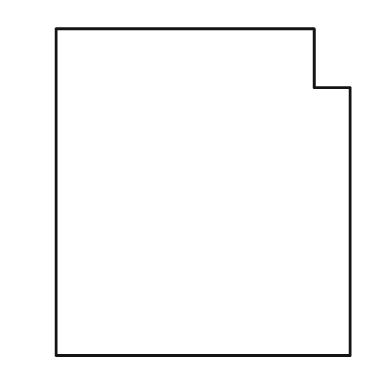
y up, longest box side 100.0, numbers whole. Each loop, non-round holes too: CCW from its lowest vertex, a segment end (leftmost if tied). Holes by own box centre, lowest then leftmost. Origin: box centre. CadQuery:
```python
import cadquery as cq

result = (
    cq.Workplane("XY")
    .moveTo(-45.0, -50.0)
    .lineTo(45.0, -50.0)
    .lineTo(45.0, 32.0)
    .lineTo(34.0, 32.0)
    .lineTo(34.0, 50.0)
    .lineTo(-45.0, 50.0)
    .close()
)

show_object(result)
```